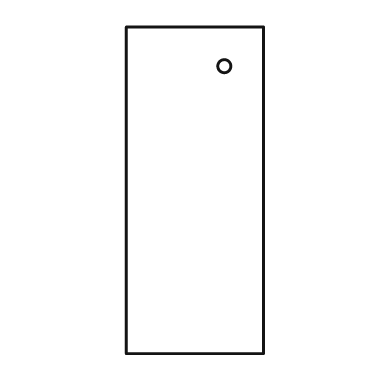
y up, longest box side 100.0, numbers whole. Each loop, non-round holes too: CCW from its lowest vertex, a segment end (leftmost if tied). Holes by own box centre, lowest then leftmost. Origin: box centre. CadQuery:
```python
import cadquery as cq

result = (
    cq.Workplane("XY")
    .moveTo(-21.0, -50.0)
    .lineTo(21.0, -50.0)
    .lineTo(21.0, 50.0)
    .lineTo(-21.0, 50.0)
    .close()
    .moveTo(9.0, 38.0)
    .circle(2.0)
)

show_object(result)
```